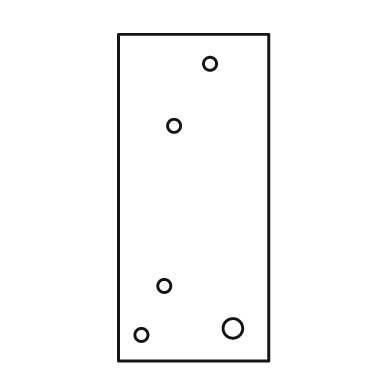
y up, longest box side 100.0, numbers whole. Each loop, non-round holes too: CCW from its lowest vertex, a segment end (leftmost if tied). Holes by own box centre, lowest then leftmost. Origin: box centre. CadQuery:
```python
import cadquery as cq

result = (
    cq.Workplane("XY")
    .moveTo(-23.0, -50.0)
    .lineTo(23.0, -50.0)
    .lineTo(23.0, 50.0)
    .lineTo(-23.0, 50.0)
    .close()
    .moveTo(-16.0, -42.0)
    .circle(2.0)
    .moveTo(12.0, -40.0)
    .circle(3.0)
    .moveTo(-9.0, -27.0)
    .circle(2.0)
    .moveTo(-6.0, 22.0)
    .circle(2.0)
    .moveTo(5.0, 41.0)
    .circle(2.0)
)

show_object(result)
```